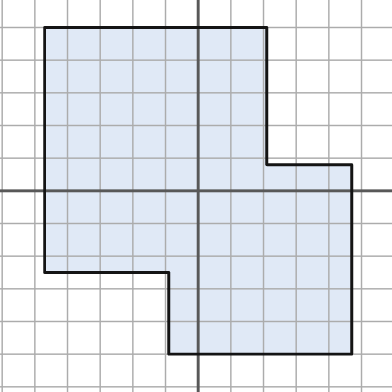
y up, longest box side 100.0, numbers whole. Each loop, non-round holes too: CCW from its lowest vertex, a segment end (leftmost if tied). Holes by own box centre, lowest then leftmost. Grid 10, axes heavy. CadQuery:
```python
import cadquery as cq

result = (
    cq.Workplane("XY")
    .moveTo(-9.0, -50.0)
    .lineTo(47.0, -50.0)
    .lineTo(47.0, 8.0)
    .lineTo(21.0, 8.0)
    .lineTo(21.0, 50.0)
    .lineTo(-47.0, 50.0)
    .lineTo(-47.0, -25.0)
    .lineTo(-9.0, -25.0)
    .close()
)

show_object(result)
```